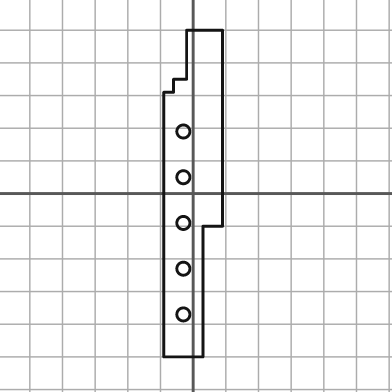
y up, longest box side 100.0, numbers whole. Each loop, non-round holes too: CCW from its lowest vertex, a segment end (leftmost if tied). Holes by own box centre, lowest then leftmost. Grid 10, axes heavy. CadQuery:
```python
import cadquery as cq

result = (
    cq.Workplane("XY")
    .moveTo(-9.0, -50.0)
    .lineTo(3.0, -50.0)
    .lineTo(3.0, -10.0)
    .lineTo(9.0, -10.0)
    .lineTo(9.0, 50.0)
    .lineTo(-2.0, 50.0)
    .lineTo(-2.0, 35.0)
    .lineTo(-6.0, 35.0)
    .lineTo(-6.0, 31.0)
    .lineTo(-9.0, 31.0)
    .close()
    .moveTo(-3.0, -37.0)
    .circle(2.0)
    .moveTo(-3.0, -23.0)
    .circle(2.0)
    .moveTo(-3.0, -9.0)
    .circle(2.0)
    .moveTo(-3.0, 5.0)
    .circle(2.0)
    .moveTo(-3.0, 19.0)
    .circle(2.0)
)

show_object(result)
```